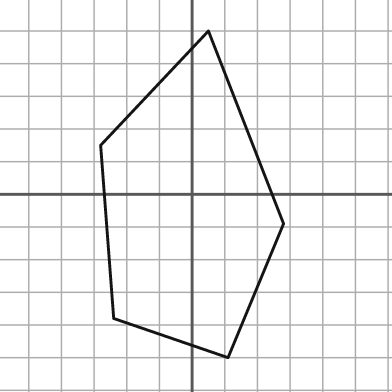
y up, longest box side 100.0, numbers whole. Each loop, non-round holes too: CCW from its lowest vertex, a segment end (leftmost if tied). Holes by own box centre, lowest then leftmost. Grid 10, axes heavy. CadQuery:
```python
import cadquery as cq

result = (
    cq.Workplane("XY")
    .moveTo(11.0, -50.0)
    .lineTo(28.0, -9.0)
    .lineTo(5.0, 50.0)
    .lineTo(-28.0, 15.0)
    .lineTo(-24.0, -38.0)
    .close()
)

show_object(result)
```